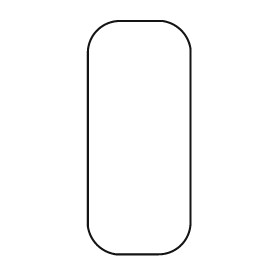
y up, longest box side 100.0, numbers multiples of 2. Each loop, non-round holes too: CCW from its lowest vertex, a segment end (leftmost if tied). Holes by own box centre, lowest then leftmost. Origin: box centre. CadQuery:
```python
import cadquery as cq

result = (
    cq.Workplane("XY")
    .moveTo(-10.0, -50.0)
    .lineTo(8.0, -50.0)
    .threePointArc((18.0, -46.0), (22.0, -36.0))
    .lineTo(22.0, 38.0)
    .threePointArc((18.0, 46.0), (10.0, 50.0))
    .lineTo(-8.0, 50.0)
    .threePointArc((-18.0, 46.0), (-22.0, 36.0))
    .lineTo(-22.0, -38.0)
    .threePointArc((-18.0, -46.0), (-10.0, -50.0))
    .close()
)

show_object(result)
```